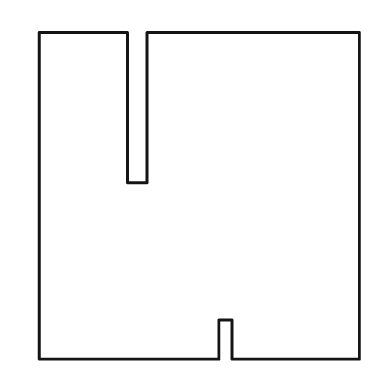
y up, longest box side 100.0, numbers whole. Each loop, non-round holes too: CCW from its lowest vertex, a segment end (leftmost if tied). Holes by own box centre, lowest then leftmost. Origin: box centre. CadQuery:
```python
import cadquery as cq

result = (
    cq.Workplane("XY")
    .moveTo(-49.0, -50.0)
    .lineTo(6.0, -50.0)
    .lineTo(6.0, -38.0)
    .lineTo(10.0, -38.0)
    .lineTo(10.0, -50.0)
    .lineTo(49.0, -50.0)
    .lineTo(49.0, 50.0)
    .lineTo(-16.0, 50.0)
    .lineTo(-16.0, 4.0)
    .lineTo(-22.0, 4.0)
    .lineTo(-22.0, 50.0)
    .lineTo(-49.0, 50.0)
    .close()
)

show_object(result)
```